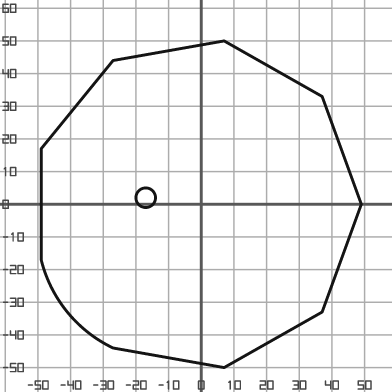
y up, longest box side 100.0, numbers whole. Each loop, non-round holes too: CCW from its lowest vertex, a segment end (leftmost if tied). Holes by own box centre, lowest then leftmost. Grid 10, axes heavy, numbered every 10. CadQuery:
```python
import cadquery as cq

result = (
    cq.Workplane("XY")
    .moveTo(7.0, -50.0)
    .lineTo(37.0, -33.0)
    .lineTo(49.0, 0.0)
    .lineTo(37.0, 33.0)
    .lineTo(7.0, 50.0)
    .lineTo(-27.0, 44.0)
    .lineTo(-49.0, 17.0)
    .lineTo(-49.0, -17.0)
    .threePointArc((-41.0, -33.0), (-27.0, -44.0))
    .close()
    .moveTo(-17.0, 2.0)
    .circle(3.0)
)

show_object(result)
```